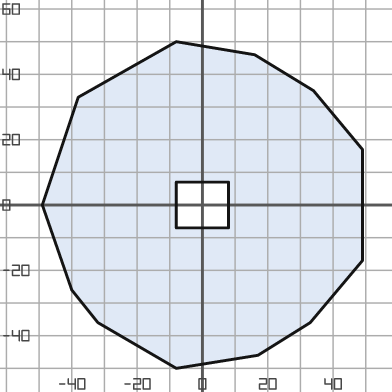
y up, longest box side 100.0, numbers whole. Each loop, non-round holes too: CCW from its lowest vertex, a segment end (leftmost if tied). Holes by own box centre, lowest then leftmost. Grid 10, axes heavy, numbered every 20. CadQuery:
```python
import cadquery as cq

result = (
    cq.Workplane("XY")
    .moveTo(-8.0, -50.0)
    .lineTo(17.0, -46.0)
    .lineTo(33.0, -36.0)
    .lineTo(49.0, -17.0)
    .lineTo(49.0, 17.0)
    .lineTo(34.0, 35.0)
    .lineTo(16.0, 46.0)
    .lineTo(-8.0, 50.0)
    .lineTo(-38.0, 33.0)
    .lineTo(-49.0, 0.0)
    .lineTo(-40.0, -26.0)
    .lineTo(-32.0, -36.0)
    .close()
    .moveTo(-8.0, -7.0)
    .lineTo(8.0, -7.0)
    .lineTo(8.0, 7.0)
    .lineTo(-8.0, 7.0)
    .close()
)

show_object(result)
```